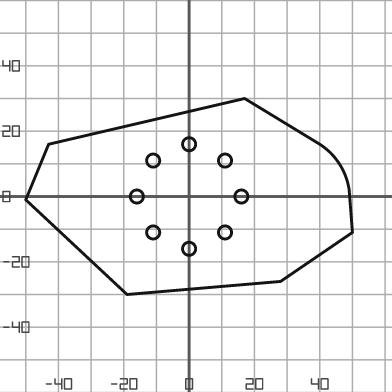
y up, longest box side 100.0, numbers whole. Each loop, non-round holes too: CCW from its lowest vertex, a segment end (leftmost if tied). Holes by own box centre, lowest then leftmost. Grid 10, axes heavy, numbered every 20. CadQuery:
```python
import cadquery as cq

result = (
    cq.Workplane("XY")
    .moveTo(-19.0, -30.0)
    .lineTo(28.0, -26.0)
    .lineTo(50.0, -11.0)
    .lineTo(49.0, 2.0)
    .threePointArc((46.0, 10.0), (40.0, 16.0))
    .lineTo(17.0, 30.0)
    .lineTo(-43.0, 16.0)
    .lineTo(-50.0, -1.0)
    .close()
    .moveTo(0.0, -16.0)
    .circle(2.0)
    .moveTo(-11.0, -11.0)
    .circle(2.0)
    .moveTo(11.0, -11.0)
    .circle(2.0)
    .moveTo(-16.0, 0.0)
    .circle(2.0)
    .moveTo(16.0, 0.0)
    .circle(2.0)
    .moveTo(-11.0, 11.0)
    .circle(2.0)
    .moveTo(11.0, 11.0)
    .circle(2.0)
    .moveTo(0.0, 16.0)
    .circle(2.0)
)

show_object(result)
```